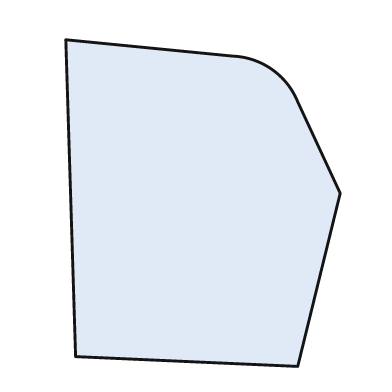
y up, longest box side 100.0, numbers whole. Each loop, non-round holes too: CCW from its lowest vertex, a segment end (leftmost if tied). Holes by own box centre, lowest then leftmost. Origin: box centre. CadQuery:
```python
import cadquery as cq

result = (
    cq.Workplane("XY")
    .moveTo(29.0, -50.0)
    .lineTo(42.0, 3.0)
    .lineTo(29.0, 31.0)
    .threePointArc((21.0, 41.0), (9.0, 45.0))
    .lineTo(-42.0, 50.0)
    .lineTo(-39.0, -47.0)
    .close()
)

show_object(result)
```